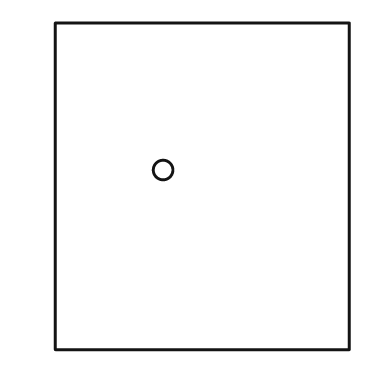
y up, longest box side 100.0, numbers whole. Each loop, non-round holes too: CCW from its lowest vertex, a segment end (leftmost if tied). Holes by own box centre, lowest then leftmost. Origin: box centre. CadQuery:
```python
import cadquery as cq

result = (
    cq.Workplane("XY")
    .moveTo(-45.0, -50.0)
    .lineTo(45.0, -50.0)
    .lineTo(45.0, 50.0)
    .lineTo(-45.0, 50.0)
    .close()
    .moveTo(-12.0, 5.0)
    .circle(3.0)
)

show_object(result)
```